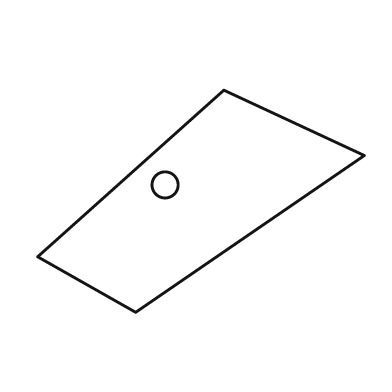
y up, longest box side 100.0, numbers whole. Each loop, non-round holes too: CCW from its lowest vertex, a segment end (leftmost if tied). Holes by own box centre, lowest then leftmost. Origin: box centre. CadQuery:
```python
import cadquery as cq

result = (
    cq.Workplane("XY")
    .moveTo(-20.0, -34.0)
    .lineTo(50.0, 14.0)
    .lineTo(7.0, 34.0)
    .lineTo(-50.0, -17.0)
    .close()
    .moveTo(-11.0, 5.0)
    .circle(4.0)
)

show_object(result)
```